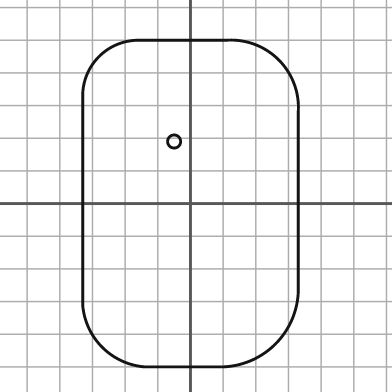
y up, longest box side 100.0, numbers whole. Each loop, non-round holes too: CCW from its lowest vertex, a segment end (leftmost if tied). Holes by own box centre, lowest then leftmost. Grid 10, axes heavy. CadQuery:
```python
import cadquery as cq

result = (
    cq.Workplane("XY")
    .moveTo(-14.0, -50.0)
    .lineTo(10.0, -50.0)
    .threePointArc((26.0, -43.0), (33.0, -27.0))
    .lineTo(33.0, 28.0)
    .threePointArc((27.0, 44.0), (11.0, 50.0))
    .lineTo(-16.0, 50.0)
    .threePointArc((-28.0, 45.0), (-33.0, 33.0))
    .lineTo(-33.0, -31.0)
    .threePointArc((-27.0, -44.0), (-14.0, -50.0))
    .close()
    .moveTo(-5.0, 19.0)
    .circle(2.0)
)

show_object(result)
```